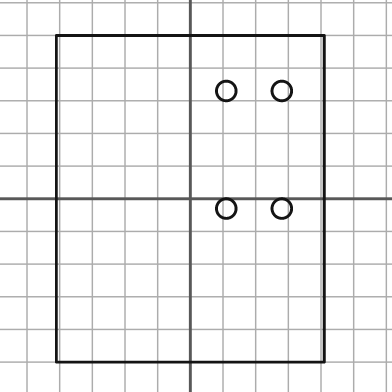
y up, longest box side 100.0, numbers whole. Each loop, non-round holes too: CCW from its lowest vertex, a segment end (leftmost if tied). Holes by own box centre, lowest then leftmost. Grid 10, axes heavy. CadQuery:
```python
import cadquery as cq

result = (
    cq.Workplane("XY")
    .moveTo(-41.0, -50.0)
    .lineTo(41.0, -50.0)
    .lineTo(41.0, 50.0)
    .lineTo(-41.0, 50.0)
    .close()
    .moveTo(11.0, -3.0)
    .circle(3.0)
    .moveTo(28.0, -3.0)
    .circle(3.0)
    .moveTo(11.0, 33.0)
    .circle(3.0)
    .moveTo(28.0, 33.0)
    .circle(3.0)
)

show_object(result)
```